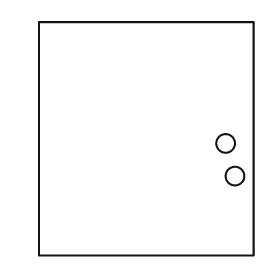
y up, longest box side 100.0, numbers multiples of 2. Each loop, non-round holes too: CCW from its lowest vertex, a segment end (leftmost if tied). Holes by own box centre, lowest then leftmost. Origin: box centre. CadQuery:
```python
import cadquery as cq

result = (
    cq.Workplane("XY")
    .moveTo(-46.0, -50.0)
    .lineTo(46.0, -50.0)
    .lineTo(46.0, 50.0)
    .lineTo(-46.0, 50.0)
    .close()
    .moveTo(38.0, -16.0)
    .circle(4.0)
    .moveTo(34.0, -2.0)
    .circle(4.0)
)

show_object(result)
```